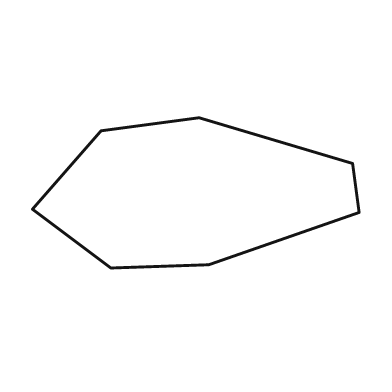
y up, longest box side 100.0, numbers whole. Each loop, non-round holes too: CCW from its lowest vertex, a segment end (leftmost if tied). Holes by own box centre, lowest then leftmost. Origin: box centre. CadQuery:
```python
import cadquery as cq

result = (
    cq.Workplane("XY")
    .moveTo(-26.0, -23.0)
    .lineTo(4.0, -22.0)
    .lineTo(50.0, -6.0)
    .lineTo(48.0, 9.0)
    .lineTo(1.0, 23.0)
    .lineTo(-29.0, 19.0)
    .lineTo(-50.0, -5.0)
    .close()
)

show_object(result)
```